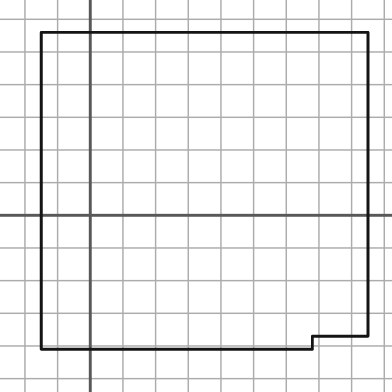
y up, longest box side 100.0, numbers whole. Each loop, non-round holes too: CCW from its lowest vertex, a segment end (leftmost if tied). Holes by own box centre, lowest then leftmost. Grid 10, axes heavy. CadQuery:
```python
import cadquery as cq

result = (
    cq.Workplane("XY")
    .moveTo(-15.0, -41.0)
    .lineTo(68.0, -41.0)
    .lineTo(68.0, -37.0)
    .lineTo(85.0, -37.0)
    .lineTo(85.0, 56.0)
    .lineTo(-15.0, 56.0)
    .close()
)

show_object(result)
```